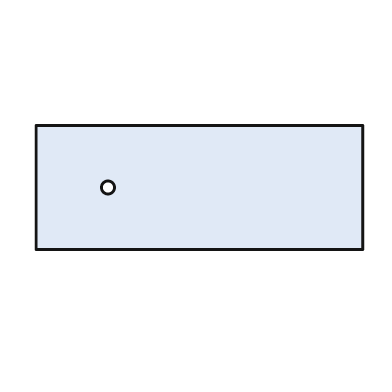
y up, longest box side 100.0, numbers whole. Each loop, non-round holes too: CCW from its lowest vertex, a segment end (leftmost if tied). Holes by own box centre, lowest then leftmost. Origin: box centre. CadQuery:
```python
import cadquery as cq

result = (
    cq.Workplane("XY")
    .moveTo(-50.0, -19.0)
    .lineTo(50.0, -19.0)
    .lineTo(50.0, 19.0)
    .lineTo(-50.0, 19.0)
    .close()
    .moveTo(-28.0, 0.0)
    .circle(2.0)
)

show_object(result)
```